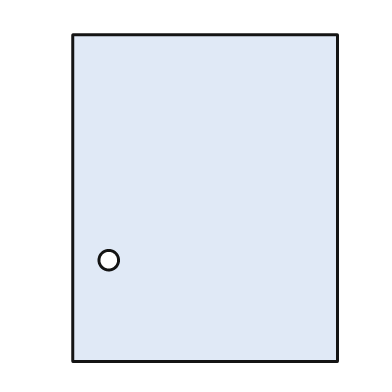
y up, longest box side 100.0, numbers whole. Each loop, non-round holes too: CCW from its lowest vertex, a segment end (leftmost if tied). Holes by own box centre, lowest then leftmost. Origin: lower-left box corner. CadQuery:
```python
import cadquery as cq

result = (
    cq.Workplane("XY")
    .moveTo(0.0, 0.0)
    .lineTo(81.0, 0.0)
    .lineTo(81.0, 100.0)
    .lineTo(0.0, 100.0)
    .close()
    .moveTo(11.0, 31.0)
    .circle(3.0)
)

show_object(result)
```